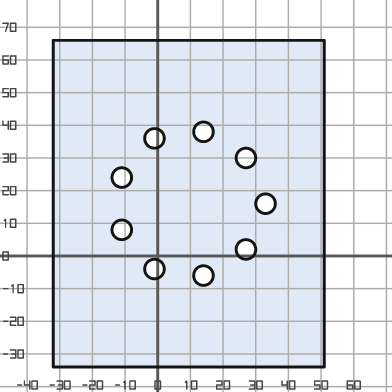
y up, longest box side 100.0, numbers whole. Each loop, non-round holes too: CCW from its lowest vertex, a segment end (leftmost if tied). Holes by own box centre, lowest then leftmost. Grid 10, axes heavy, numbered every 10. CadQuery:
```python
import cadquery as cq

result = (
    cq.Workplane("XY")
    .moveTo(-32.0, -34.0)
    .lineTo(51.0, -34.0)
    .lineTo(51.0, 66.0)
    .lineTo(-32.0, 66.0)
    .close()
    .moveTo(14.0, -6.0)
    .circle(3.0)
    .moveTo(-1.0, -4.0)
    .circle(3.0)
    .moveTo(27.0, 2.0)
    .circle(3.0)
    .moveTo(-11.0, 8.0)
    .circle(3.0)
    .moveTo(33.0, 16.0)
    .circle(3.0)
    .moveTo(-11.0, 24.0)
    .circle(3.0)
    .moveTo(27.0, 30.0)
    .circle(3.0)
    .moveTo(-1.0, 36.0)
    .circle(3.0)
    .moveTo(14.0, 38.0)
    .circle(3.0)
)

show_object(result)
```